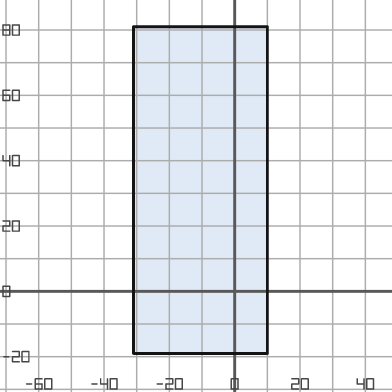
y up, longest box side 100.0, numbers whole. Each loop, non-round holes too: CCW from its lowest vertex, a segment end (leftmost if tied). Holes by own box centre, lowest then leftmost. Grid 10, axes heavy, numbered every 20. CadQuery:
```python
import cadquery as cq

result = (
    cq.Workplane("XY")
    .moveTo(-31.0, -19.0)
    .lineTo(10.0, -19.0)
    .lineTo(10.0, 81.0)
    .lineTo(-31.0, 81.0)
    .close()
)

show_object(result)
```